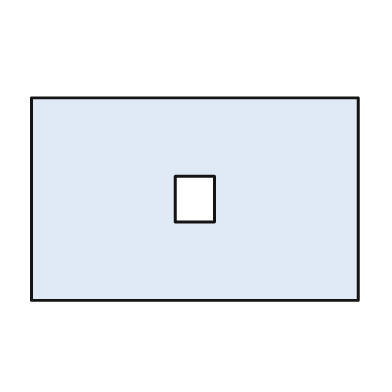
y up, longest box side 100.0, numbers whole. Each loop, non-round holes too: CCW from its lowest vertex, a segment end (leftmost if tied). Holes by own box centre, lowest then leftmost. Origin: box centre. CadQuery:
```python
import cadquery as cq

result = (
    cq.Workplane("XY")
    .moveTo(-50.0, -31.0)
    .lineTo(50.0, -31.0)
    .lineTo(50.0, 31.0)
    .lineTo(-50.0, 31.0)
    .close()
    .moveTo(-6.0, -7.0)
    .lineTo(6.0, -7.0)
    .lineTo(6.0, 7.0)
    .lineTo(-6.0, 7.0)
    .close()
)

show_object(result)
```